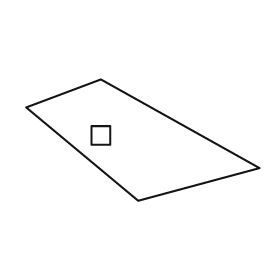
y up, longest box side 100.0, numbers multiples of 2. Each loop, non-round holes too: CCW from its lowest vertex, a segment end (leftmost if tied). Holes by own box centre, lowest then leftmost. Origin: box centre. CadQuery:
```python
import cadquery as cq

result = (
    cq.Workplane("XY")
    .moveTo(-2.0, -26.0)
    .lineTo(50.0, -12.0)
    .lineTo(-18.0, 26.0)
    .lineTo(-50.0, 14.0)
    .close()
    .moveTo(-22.0, -2.0)
    .lineTo(-14.0, -2.0)
    .lineTo(-14.0, 6.0)
    .lineTo(-22.0, 6.0)
    .close()
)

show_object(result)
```